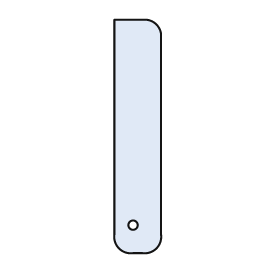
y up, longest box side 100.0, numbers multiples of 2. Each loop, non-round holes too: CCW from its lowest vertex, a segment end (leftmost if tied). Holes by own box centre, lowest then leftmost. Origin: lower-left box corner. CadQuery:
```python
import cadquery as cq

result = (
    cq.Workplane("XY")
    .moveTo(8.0, 0.0)
    .lineTo(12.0, 0.0)
    .threePointArc((18.0, 2.0), (20.0, 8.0))
    .lineTo(20.0, 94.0)
    .threePointArc((18.0, 98.0), (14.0, 100.0))
    .lineTo(0.0, 100.0)
    .lineTo(0.0, 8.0)
    .threePointArc((2.0, 2.0), (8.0, 0.0))
    .close()
    .moveTo(8.0, 12.0)
    .circle(2.0)
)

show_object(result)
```